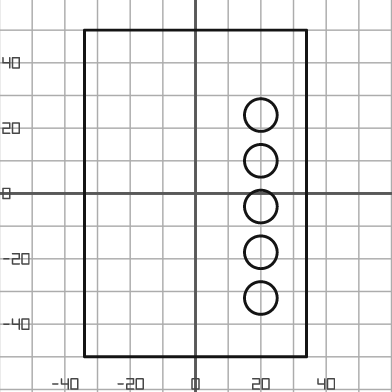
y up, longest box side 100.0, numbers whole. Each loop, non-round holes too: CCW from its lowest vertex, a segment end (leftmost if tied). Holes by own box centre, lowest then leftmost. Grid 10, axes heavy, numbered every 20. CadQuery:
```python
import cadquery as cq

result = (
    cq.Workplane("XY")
    .moveTo(-34.0, -50.0)
    .lineTo(34.0, -50.0)
    .lineTo(34.0, 50.0)
    .lineTo(-34.0, 50.0)
    .close()
    .moveTo(20.0, -32.0)
    .circle(5.0)
    .moveTo(20.0, -18.0)
    .circle(5.0)
    .moveTo(20.0, -4.0)
    .circle(5.0)
    .moveTo(20.0, 10.0)
    .circle(5.0)
    .moveTo(20.0, 24.0)
    .circle(5.0)
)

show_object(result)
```